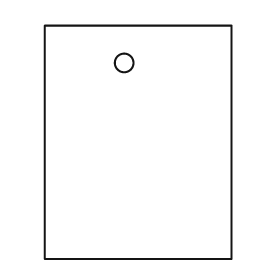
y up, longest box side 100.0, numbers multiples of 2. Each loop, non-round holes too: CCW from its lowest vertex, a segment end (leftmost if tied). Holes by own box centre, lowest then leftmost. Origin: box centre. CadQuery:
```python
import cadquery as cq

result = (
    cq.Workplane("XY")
    .moveTo(-40.0, -50.0)
    .lineTo(40.0, -50.0)
    .lineTo(40.0, 50.0)
    .lineTo(-40.0, 50.0)
    .close()
    .moveTo(-6.0, 34.0)
    .circle(4.0)
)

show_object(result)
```